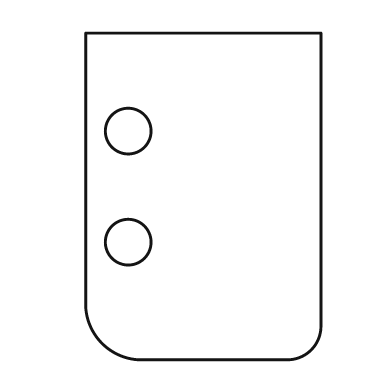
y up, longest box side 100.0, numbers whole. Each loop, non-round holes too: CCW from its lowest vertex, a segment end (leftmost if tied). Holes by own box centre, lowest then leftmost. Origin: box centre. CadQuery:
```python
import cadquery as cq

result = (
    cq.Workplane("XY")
    .moveTo(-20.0, -50.0)
    .lineTo(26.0, -50.0)
    .threePointArc((33.0, -47.0), (36.0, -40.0))
    .lineTo(36.0, 50.0)
    .lineTo(-36.0, 50.0)
    .lineTo(-36.0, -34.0)
    .threePointArc((-31.0, -45.0), (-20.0, -50.0))
    .close()
    .moveTo(-23.0, -14.0)
    .circle(7.0)
    .moveTo(-23.0, 20.0)
    .circle(7.0)
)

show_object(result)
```